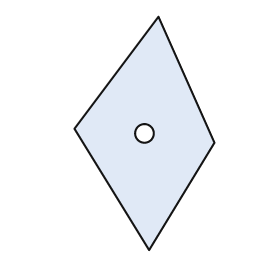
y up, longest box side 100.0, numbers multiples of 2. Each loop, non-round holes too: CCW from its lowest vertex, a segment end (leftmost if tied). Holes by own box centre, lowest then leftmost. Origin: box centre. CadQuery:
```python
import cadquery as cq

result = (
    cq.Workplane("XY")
    .moveTo(2.0, -50.0)
    .lineTo(30.0, -4.0)
    .lineTo(6.0, 50.0)
    .lineTo(-30.0, 2.0)
    .close()
    .moveTo(0.0, 0.0)
    .circle(4.0)
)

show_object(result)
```